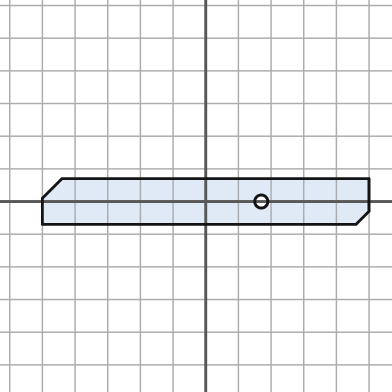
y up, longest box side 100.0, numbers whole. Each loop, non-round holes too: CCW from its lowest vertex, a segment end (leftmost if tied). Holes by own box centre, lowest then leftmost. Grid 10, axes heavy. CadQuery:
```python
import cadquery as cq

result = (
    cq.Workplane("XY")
    .moveTo(-50.0, -7.0)
    .lineTo(46.0, -7.0)
    .lineTo(50.0, -3.0)
    .lineTo(50.0, 7.0)
    .lineTo(-44.0, 7.0)
    .lineTo(-50.0, 1.0)
    .close()
    .moveTo(17.0, 0.0)
    .circle(2.0)
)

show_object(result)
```